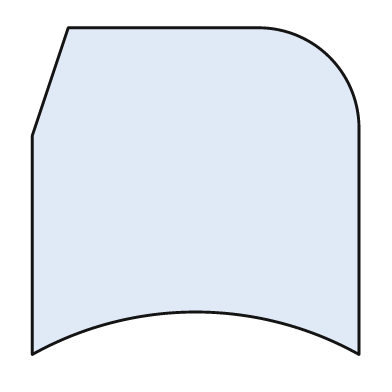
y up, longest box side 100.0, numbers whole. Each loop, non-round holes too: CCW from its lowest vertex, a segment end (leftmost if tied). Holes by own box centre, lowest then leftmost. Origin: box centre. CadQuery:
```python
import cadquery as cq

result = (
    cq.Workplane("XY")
    .moveTo(-50.0, -50.0)
    .threePointArc((0.0, -37.0), (50.0, -50.0))
    .lineTo(50.0, 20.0)
    .threePointArc((41.0, 41.0), (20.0, 50.0))
    .lineTo(-39.0, 50.0)
    .lineTo(-50.0, 17.0)
    .close()
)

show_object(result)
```